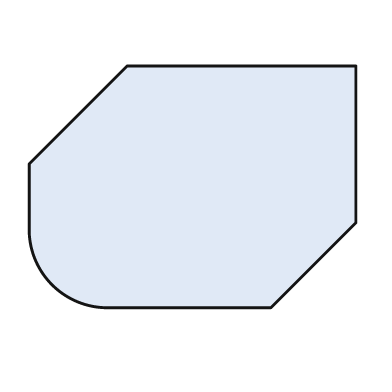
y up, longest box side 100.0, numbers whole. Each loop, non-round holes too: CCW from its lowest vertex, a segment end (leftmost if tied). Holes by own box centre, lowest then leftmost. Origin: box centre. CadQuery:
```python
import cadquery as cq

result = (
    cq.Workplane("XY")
    .moveTo(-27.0, -37.0)
    .lineTo(24.0, -37.0)
    .lineTo(50.0, -11.0)
    .lineTo(50.0, 37.0)
    .lineTo(-20.0, 37.0)
    .lineTo(-50.0, 7.0)
    .lineTo(-50.0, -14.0)
    .threePointArc((-43.0, -30.0), (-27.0, -37.0))
    .close()
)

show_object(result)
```